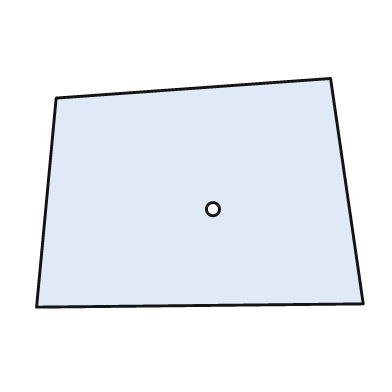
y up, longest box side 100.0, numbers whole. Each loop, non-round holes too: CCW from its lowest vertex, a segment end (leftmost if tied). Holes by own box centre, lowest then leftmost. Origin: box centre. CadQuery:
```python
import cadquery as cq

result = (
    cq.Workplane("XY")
    .moveTo(-50.0, -35.0)
    .lineTo(50.0, -34.0)
    .lineTo(40.0, 35.0)
    .lineTo(-44.0, 29.0)
    .close()
    .moveTo(4.0, -5.0)
    .circle(2.0)
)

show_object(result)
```